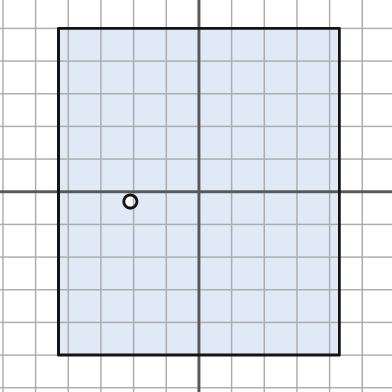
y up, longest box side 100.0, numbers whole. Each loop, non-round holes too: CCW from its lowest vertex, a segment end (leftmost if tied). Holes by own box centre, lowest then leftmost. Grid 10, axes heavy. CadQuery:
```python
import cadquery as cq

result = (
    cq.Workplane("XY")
    .moveTo(-43.0, -50.0)
    .lineTo(43.0, -50.0)
    .lineTo(43.0, 50.0)
    .lineTo(-43.0, 50.0)
    .close()
    .moveTo(-21.0, -3.0)
    .circle(2.0)
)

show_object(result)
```